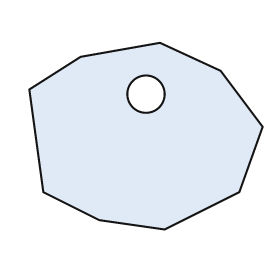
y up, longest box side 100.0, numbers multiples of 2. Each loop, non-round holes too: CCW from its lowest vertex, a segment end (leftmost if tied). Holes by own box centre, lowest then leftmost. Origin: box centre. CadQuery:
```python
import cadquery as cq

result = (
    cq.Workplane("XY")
    .moveTo(8.0, -40.0)
    .lineTo(40.0, -24.0)
    .lineTo(50.0, 4.0)
    .lineTo(32.0, 28.0)
    .lineTo(6.0, 40.0)
    .lineTo(-28.0, 34.0)
    .lineTo(-50.0, 20.0)
    .lineTo(-44.0, -24.0)
    .lineTo(-20.0, -36.0)
    .close()
    .moveTo(0.0, 18.0)
    .circle(8.0)
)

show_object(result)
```